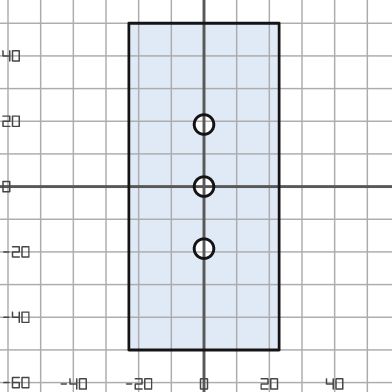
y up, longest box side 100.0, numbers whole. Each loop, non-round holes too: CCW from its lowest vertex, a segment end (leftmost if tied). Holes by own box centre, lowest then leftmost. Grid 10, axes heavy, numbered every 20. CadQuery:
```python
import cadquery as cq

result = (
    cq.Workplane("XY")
    .moveTo(-23.0, -50.0)
    .lineTo(23.0, -50.0)
    .lineTo(23.0, 50.0)
    .lineTo(-23.0, 50.0)
    .close()
    .moveTo(0.0, -19.0)
    .circle(3.0)
    .moveTo(0.0, 0.0)
    .circle(3.0)
    .moveTo(0.0, 19.0)
    .circle(3.0)
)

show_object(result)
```